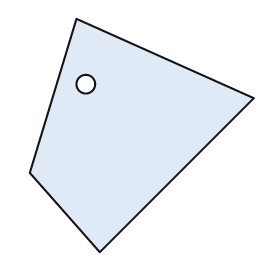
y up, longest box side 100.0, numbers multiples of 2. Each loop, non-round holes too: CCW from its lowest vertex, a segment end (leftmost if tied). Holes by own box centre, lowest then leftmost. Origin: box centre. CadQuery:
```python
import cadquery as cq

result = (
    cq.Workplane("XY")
    .moveTo(-18.0, -50.0)
    .lineTo(48.0, 16.0)
    .lineTo(-28.0, 50.0)
    .lineTo(-48.0, -16.0)
    .close()
    .moveTo(-24.0, 22.0)
    .circle(4.0)
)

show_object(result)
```